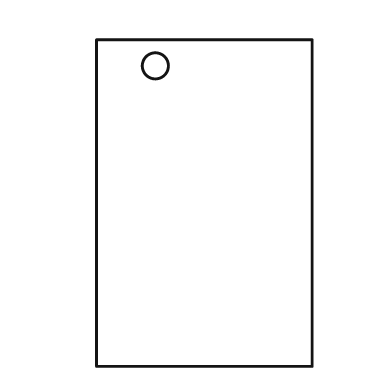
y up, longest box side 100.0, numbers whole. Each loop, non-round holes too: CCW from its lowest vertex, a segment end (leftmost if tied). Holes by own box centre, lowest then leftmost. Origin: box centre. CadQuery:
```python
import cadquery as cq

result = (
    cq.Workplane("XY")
    .moveTo(-33.0, -50.0)
    .lineTo(33.0, -50.0)
    .lineTo(33.0, 50.0)
    .lineTo(-33.0, 50.0)
    .close()
    .moveTo(-15.0, 42.0)
    .circle(4.0)
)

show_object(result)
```